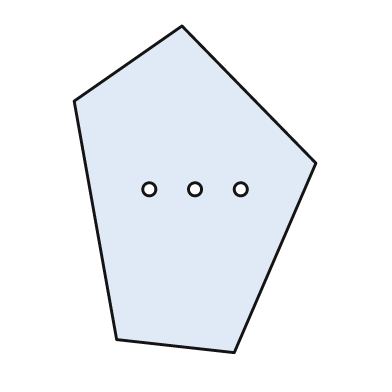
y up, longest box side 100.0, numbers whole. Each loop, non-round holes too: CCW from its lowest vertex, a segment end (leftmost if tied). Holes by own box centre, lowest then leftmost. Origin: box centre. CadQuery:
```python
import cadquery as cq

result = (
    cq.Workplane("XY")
    .moveTo(12.0, -50.0)
    .lineTo(37.0, 8.0)
    .lineTo(-4.0, 50.0)
    .lineTo(-37.0, 27.0)
    .lineTo(-24.0, -46.0)
    .close()
    .moveTo(-14.0, 0.0)
    .circle(2.0)
    .moveTo(0.0, 0.0)
    .circle(2.0)
    .moveTo(14.0, 0.0)
    .circle(2.0)
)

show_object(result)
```